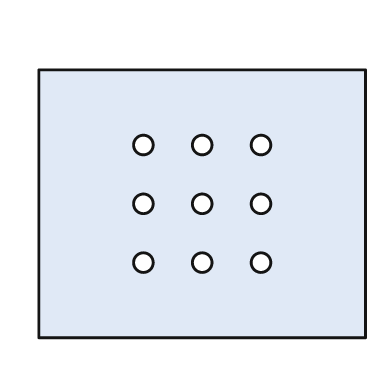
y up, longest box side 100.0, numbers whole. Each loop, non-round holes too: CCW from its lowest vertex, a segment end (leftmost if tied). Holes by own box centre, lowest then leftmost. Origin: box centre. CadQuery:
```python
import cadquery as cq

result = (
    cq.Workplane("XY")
    .moveTo(-50.0, -41.0)
    .lineTo(50.0, -41.0)
    .lineTo(50.0, 41.0)
    .lineTo(-50.0, 41.0)
    .close()
    .moveTo(-18.0, -18.0)
    .circle(3.0)
    .moveTo(0.0, -18.0)
    .circle(3.0)
    .moveTo(18.0, -18.0)
    .circle(3.0)
    .moveTo(-18.0, 0.0)
    .circle(3.0)
    .moveTo(0.0, 0.0)
    .circle(3.0)
    .moveTo(18.0, 0.0)
    .circle(3.0)
    .moveTo(-18.0, 18.0)
    .circle(3.0)
    .moveTo(0.0, 18.0)
    .circle(3.0)
    .moveTo(18.0, 18.0)
    .circle(3.0)
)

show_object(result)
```